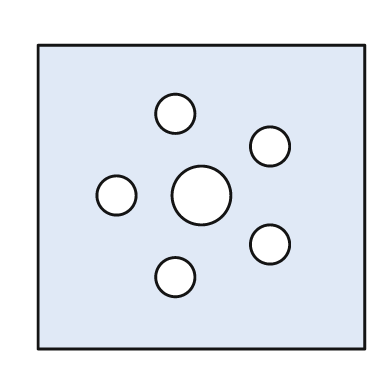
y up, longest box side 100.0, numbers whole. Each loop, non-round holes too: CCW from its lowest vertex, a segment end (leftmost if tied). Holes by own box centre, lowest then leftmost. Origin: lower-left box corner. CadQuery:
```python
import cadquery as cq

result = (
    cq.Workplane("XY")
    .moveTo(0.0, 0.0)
    .lineTo(100.0, 0.0)
    .lineTo(100.0, 93.0)
    .lineTo(0.0, 93.0)
    .close()
    .moveTo(42.0, 22.0)
    .circle(6.0)
    .moveTo(71.0, 32.0)
    .circle(6.0)
    .moveTo(24.0, 47.0)
    .circle(6.0)
    .moveTo(50.0, 47.0)
    .circle(9.0)
    .moveTo(71.0, 62.0)
    .circle(6.0)
    .moveTo(42.0, 72.0)
    .circle(6.0)
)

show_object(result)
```